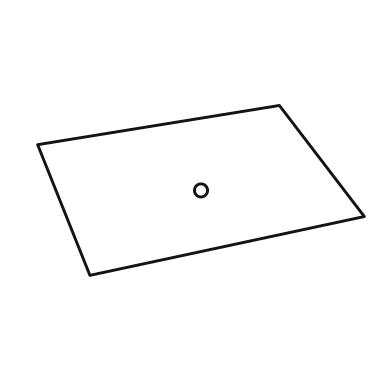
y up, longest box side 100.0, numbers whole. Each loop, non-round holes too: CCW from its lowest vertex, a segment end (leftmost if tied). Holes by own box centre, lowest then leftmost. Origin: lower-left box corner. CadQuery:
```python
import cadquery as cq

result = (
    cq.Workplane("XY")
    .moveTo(16.0, 0.0)
    .lineTo(100.0, 18.0)
    .lineTo(74.0, 52.0)
    .lineTo(0.0, 40.0)
    .close()
    .moveTo(50.0, 26.0)
    .circle(2.0)
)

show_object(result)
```